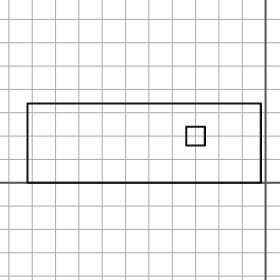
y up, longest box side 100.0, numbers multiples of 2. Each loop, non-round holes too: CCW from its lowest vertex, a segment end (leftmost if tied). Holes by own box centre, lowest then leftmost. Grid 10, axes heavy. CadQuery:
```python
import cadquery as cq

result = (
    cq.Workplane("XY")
    .moveTo(-102.0, 0.0)
    .lineTo(-2.0, 0.0)
    .lineTo(-2.0, 34.0)
    .lineTo(-102.0, 34.0)
    .close()
    .moveTo(-34.0, 16.0)
    .lineTo(-26.0, 16.0)
    .lineTo(-26.0, 24.0)
    .lineTo(-34.0, 24.0)
    .close()
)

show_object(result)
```